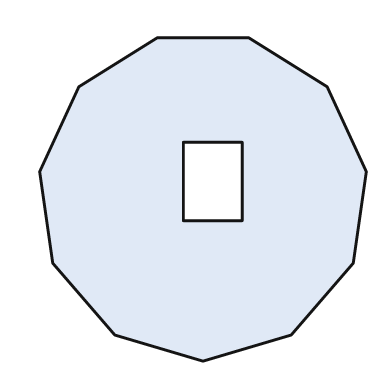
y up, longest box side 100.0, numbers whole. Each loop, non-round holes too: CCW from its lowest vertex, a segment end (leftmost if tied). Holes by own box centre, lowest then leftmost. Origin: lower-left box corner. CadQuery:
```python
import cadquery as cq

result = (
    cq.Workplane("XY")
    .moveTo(50.0, 0.0)
    .lineTo(77.0, 8.0)
    .lineTo(96.0, 30.0)
    .lineTo(100.0, 58.0)
    .lineTo(88.0, 84.0)
    .lineTo(64.0, 99.0)
    .lineTo(36.0, 99.0)
    .lineTo(12.0, 84.0)
    .lineTo(0.0, 58.0)
    .lineTo(4.0, 30.0)
    .lineTo(23.0, 8.0)
    .close()
    .moveTo(44.0, 43.0)
    .lineTo(62.0, 43.0)
    .lineTo(62.0, 67.0)
    .lineTo(44.0, 67.0)
    .close()
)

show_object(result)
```